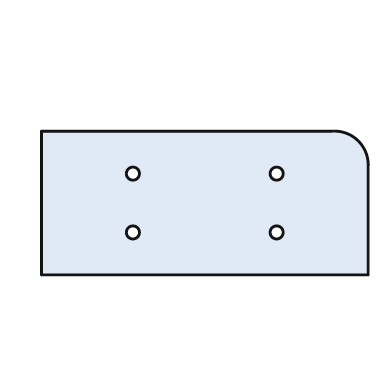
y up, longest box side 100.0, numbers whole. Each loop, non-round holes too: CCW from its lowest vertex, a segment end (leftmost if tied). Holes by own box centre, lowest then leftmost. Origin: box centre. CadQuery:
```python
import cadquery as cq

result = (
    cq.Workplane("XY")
    .moveTo(-50.0, -22.0)
    .lineTo(50.0, -22.0)
    .lineTo(50.0, 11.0)
    .threePointArc((47.0, 19.0), (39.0, 22.0))
    .lineTo(-50.0, 22.0)
    .close()
    .moveTo(-22.0, -9.0)
    .circle(2.0)
    .moveTo(22.0, -9.0)
    .circle(2.0)
    .moveTo(-22.0, 9.0)
    .circle(2.0)
    .moveTo(22.0, 9.0)
    .circle(2.0)
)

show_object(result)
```